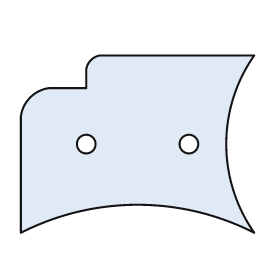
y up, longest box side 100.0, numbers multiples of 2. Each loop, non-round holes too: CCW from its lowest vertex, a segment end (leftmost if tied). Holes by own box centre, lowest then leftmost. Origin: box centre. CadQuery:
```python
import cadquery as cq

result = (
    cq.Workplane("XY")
    .moveTo(-50.0, -38.0)
    .threePointArc((0.0, -26.0), (50.0, -38.0))
    .threePointArc((38.0, 0.0), (50.0, 38.0))
    .lineTo(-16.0, 38.0)
    .threePointArc((-20.0, 36.0), (-22.0, 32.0))
    .lineTo(-22.0, 24.0)
    .lineTo(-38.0, 24.0)
    .threePointArc((-46.0, 20.0), (-50.0, 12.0))
    .close()
    .moveTo(-22.0, 0.0)
    .circle(4.0)
    .moveTo(22.0, 0.0)
    .circle(4.0)
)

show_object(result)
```